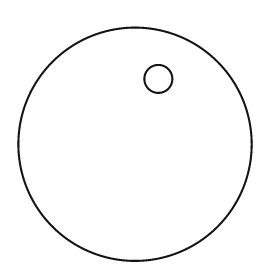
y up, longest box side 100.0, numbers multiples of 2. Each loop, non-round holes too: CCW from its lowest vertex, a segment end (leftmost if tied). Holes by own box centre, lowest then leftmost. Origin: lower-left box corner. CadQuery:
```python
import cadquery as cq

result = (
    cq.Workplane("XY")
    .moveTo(50.0, 50.0)
    .circle(50.0)
    .moveTo(60.0, 78.0)
    .circle(6.0)
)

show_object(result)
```